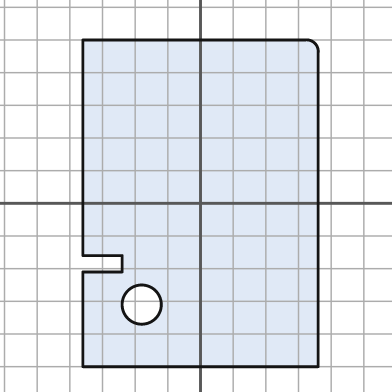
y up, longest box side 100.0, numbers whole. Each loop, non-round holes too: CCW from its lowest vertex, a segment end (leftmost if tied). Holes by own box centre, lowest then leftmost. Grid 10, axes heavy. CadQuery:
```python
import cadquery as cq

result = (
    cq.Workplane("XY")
    .moveTo(-36.0, -50.0)
    .lineTo(36.0, -50.0)
    .lineTo(36.0, 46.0)
    .threePointArc((35.0, 49.0), (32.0, 50.0))
    .lineTo(-36.0, 50.0)
    .lineTo(-36.0, -16.0)
    .lineTo(-24.0, -16.0)
    .lineTo(-24.0, -21.0)
    .lineTo(-36.0, -21.0)
    .close()
    .moveTo(-18.0, -31.0)
    .circle(6.0)
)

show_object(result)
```